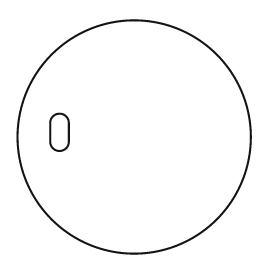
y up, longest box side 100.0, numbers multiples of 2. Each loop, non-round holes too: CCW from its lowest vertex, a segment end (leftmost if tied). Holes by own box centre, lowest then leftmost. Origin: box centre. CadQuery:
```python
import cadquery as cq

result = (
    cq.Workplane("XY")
    .moveTo(0.0, 0.0)
    .circle(50.0)
    .moveTo(-36.0, -2.0)
    .threePointArc((-32.0, -6.0), (-28.0, -2.0))
    .lineTo(-28.0, 6.0)
    .threePointArc((-32.0, 10.0), (-36.0, 6.0))
    .close()
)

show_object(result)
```